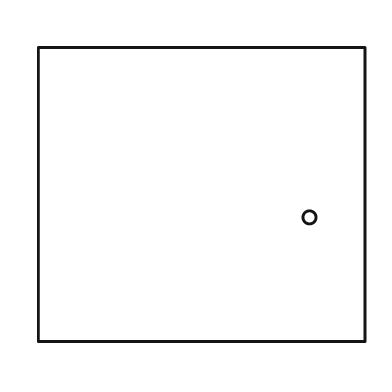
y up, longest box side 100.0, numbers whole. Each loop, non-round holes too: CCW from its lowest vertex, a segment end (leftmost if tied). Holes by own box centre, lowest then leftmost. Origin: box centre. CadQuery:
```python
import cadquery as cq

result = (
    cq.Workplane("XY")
    .moveTo(-50.0, -45.0)
    .lineTo(50.0, -45.0)
    .lineTo(50.0, 45.0)
    .lineTo(-50.0, 45.0)
    .close()
    .moveTo(33.0, -7.0)
    .circle(2.0)
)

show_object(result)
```